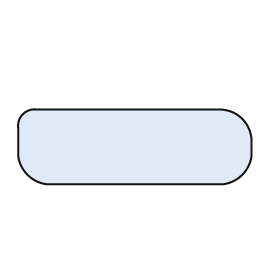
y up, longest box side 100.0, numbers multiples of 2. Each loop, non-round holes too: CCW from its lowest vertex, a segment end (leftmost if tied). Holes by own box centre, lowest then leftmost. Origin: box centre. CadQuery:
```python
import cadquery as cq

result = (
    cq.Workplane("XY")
    .moveTo(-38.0, -16.0)
    .lineTo(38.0, -16.0)
    .threePointArc((46.0, -12.0), (50.0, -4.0))
    .lineTo(50.0, 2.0)
    .threePointArc((46.0, 12.0), (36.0, 16.0))
    .lineTo(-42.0, 16.0)
    .threePointArc((-48.0, 14.0), (-50.0, 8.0))
    .lineTo(-50.0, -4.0)
    .threePointArc((-46.0, -12.0), (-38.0, -16.0))
    .close()
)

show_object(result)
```